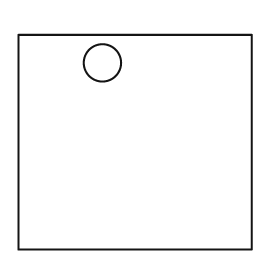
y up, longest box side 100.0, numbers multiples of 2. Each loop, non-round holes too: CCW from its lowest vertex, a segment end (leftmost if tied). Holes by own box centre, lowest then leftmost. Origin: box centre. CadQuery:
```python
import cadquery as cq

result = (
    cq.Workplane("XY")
    .moveTo(-50.0, -46.0)
    .lineTo(50.0, -46.0)
    .lineTo(50.0, 46.0)
    .lineTo(-50.0, 46.0)
    .close()
    .moveTo(-14.0, 34.0)
    .circle(8.0)
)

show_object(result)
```